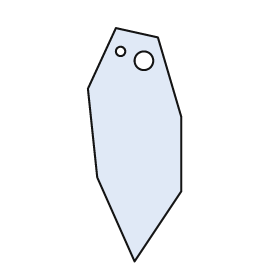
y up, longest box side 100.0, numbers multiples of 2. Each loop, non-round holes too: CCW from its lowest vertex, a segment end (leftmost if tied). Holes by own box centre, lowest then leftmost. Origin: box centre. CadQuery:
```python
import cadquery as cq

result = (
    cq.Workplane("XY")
    .moveTo(0.0, -50.0)
    .lineTo(20.0, -20.0)
    .lineTo(20.0, 12.0)
    .lineTo(10.0, 46.0)
    .lineTo(-8.0, 50.0)
    .lineTo(-20.0, 24.0)
    .lineTo(-16.0, -14.0)
    .close()
    .moveTo(4.0, 36.0)
    .circle(4.0)
    .moveTo(-6.0, 40.0)
    .circle(2.0)
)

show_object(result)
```